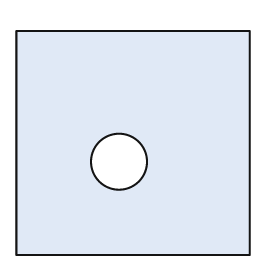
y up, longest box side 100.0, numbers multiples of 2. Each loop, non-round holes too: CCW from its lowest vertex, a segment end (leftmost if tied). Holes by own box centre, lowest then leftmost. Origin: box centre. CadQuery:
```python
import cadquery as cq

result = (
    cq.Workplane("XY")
    .moveTo(-50.0, -48.0)
    .lineTo(50.0, -48.0)
    .lineTo(50.0, 48.0)
    .lineTo(-50.0, 48.0)
    .close()
    .moveTo(-6.0, -8.0)
    .circle(12.0)
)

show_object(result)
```